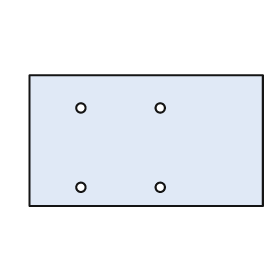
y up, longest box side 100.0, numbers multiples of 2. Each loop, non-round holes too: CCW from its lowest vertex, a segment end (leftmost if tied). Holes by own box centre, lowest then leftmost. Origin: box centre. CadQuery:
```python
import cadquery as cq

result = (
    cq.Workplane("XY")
    .moveTo(-50.0, -28.0)
    .lineTo(50.0, -28.0)
    .lineTo(50.0, 28.0)
    .lineTo(-50.0, 28.0)
    .close()
    .moveTo(-28.0, -20.0)
    .circle(2.0)
    .moveTo(6.0, -20.0)
    .circle(2.0)
    .moveTo(-28.0, 14.0)
    .circle(2.0)
    .moveTo(6.0, 14.0)
    .circle(2.0)
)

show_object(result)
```